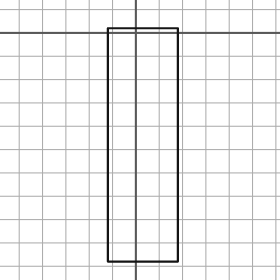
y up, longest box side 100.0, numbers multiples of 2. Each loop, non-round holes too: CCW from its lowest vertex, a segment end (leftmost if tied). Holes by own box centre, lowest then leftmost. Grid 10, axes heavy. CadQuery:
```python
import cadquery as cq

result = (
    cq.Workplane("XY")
    .moveTo(-12.0, -98.0)
    .lineTo(18.0, -98.0)
    .lineTo(18.0, 2.0)
    .lineTo(-12.0, 2.0)
    .close()
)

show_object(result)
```